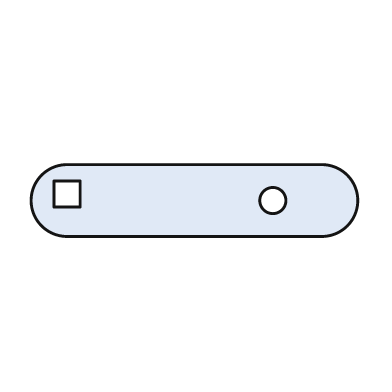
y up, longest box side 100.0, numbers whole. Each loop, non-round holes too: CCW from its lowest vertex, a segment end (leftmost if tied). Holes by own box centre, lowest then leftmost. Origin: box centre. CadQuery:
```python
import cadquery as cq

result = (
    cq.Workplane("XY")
    .moveTo(-39.0, -11.0)
    .lineTo(39.0, -11.0)
    .threePointArc((50.0, 0.0), (39.0, 11.0))
    .lineTo(-39.0, 11.0)
    .threePointArc((-50.0, 0.0), (-39.0, -11.0))
    .close()
    .moveTo(24.0, 0.0)
    .circle(4.0)
    .moveTo(-43.0, -2.0)
    .lineTo(-35.0, -2.0)
    .lineTo(-35.0, 6.0)
    .lineTo(-43.0, 6.0)
    .close()
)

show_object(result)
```